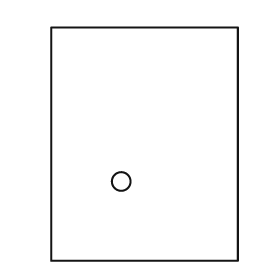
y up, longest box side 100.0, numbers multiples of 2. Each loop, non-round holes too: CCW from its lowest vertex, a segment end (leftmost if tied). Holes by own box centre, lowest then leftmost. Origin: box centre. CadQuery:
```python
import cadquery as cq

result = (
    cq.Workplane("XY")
    .moveTo(-40.0, -50.0)
    .lineTo(40.0, -50.0)
    .lineTo(40.0, 50.0)
    .lineTo(-40.0, 50.0)
    .close()
    .moveTo(-10.0, -16.0)
    .circle(4.0)
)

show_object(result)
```